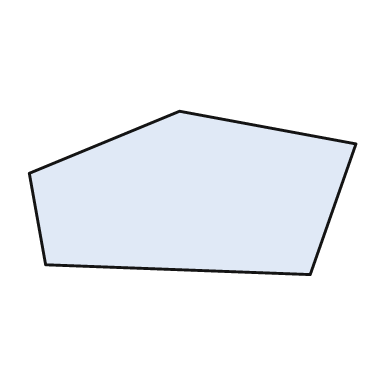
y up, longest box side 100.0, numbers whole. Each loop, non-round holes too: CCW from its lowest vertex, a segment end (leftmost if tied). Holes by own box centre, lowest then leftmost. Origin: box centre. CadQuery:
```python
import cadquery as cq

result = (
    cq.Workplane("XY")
    .moveTo(36.0, -25.0)
    .lineTo(50.0, 15.0)
    .lineTo(-4.0, 25.0)
    .lineTo(-50.0, 6.0)
    .lineTo(-45.0, -22.0)
    .close()
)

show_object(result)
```